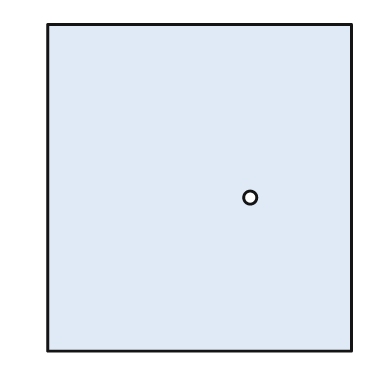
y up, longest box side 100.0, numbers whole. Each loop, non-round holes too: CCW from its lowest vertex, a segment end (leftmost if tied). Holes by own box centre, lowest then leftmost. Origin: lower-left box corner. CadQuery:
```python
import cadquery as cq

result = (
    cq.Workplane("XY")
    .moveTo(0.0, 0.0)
    .lineTo(93.0, 0.0)
    .lineTo(93.0, 100.0)
    .lineTo(0.0, 100.0)
    .close()
    .moveTo(62.0, 47.0)
    .circle(2.0)
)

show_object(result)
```